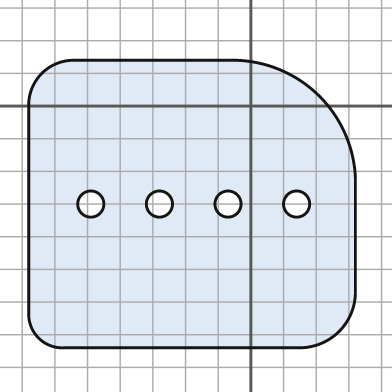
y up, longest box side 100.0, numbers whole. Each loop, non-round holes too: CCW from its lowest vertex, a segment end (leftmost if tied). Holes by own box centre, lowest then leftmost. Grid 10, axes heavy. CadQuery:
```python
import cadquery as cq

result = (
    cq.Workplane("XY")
    .moveTo(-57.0, -74.0)
    .lineTo(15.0, -74.0)
    .threePointArc((27.0, -69.0), (32.0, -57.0))
    .lineTo(32.0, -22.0)
    .threePointArc((21.0, 3.0), (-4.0, 14.0))
    .lineTo(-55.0, 14.0)
    .threePointArc((-64.0, 10.0), (-68.0, 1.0))
    .lineTo(-68.0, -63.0)
    .threePointArc((-65.0, -71.0), (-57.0, -74.0))
    .close()
    .moveTo(-49.0, -30.0)
    .circle(4.0)
    .moveTo(-28.0, -30.0)
    .circle(4.0)
    .moveTo(-7.0, -30.0)
    .circle(4.0)
    .moveTo(14.0, -30.0)
    .circle(4.0)
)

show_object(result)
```